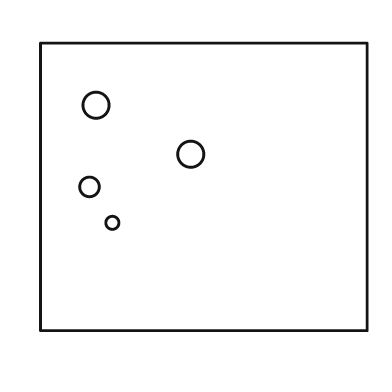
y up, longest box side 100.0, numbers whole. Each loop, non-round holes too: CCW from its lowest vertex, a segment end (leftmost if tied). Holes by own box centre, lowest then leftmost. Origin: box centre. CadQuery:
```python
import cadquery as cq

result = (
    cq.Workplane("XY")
    .moveTo(-50.0, -44.0)
    .lineTo(50.0, -44.0)
    .lineTo(50.0, 44.0)
    .lineTo(-50.0, 44.0)
    .close()
    .moveTo(-28.0, -11.0)
    .circle(2.0)
    .moveTo(-35.0, 0.0)
    .circle(3.0)
    .moveTo(-4.0, 10.0)
    .circle(4.0)
    .moveTo(-33.0, 25.0)
    .circle(4.0)
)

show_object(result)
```